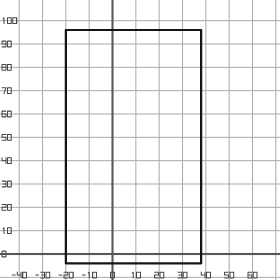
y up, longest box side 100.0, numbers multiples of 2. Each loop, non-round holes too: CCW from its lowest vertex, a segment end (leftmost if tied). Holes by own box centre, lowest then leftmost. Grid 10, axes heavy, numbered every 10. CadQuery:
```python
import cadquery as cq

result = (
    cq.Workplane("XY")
    .moveTo(-20.0, -4.0)
    .lineTo(38.0, -4.0)
    .lineTo(38.0, 96.0)
    .lineTo(-20.0, 96.0)
    .close()
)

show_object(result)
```